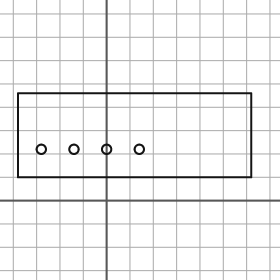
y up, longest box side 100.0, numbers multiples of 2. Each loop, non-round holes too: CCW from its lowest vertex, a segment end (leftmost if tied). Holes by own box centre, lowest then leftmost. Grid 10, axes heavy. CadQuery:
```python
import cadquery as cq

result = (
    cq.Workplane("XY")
    .moveTo(-38.0, 10.0)
    .lineTo(62.0, 10.0)
    .lineTo(62.0, 46.0)
    .lineTo(-38.0, 46.0)
    .close()
    .moveTo(-28.0, 22.0)
    .circle(2.0)
    .moveTo(-14.0, 22.0)
    .circle(2.0)
    .moveTo(0.0, 22.0)
    .circle(2.0)
    .moveTo(14.0, 22.0)
    .circle(2.0)
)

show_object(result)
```